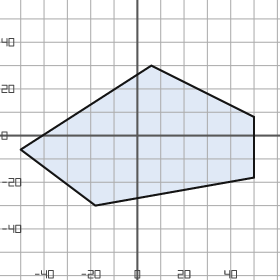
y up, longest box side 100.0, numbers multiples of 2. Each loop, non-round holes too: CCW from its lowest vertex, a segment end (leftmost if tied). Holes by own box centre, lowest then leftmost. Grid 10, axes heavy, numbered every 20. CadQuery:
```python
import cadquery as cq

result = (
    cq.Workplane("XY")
    .moveTo(-18.0, -30.0)
    .lineTo(50.0, -18.0)
    .lineTo(50.0, 8.0)
    .lineTo(6.0, 30.0)
    .lineTo(-50.0, -6.0)
    .close()
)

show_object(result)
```